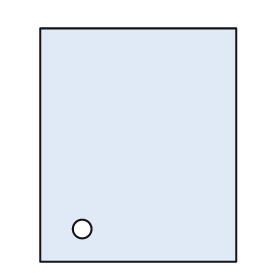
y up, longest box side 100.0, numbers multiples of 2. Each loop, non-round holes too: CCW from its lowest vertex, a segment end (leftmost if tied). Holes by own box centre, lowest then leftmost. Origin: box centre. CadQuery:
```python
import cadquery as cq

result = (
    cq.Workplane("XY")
    .moveTo(-42.0, -50.0)
    .lineTo(42.0, -50.0)
    .lineTo(42.0, 50.0)
    .lineTo(-42.0, 50.0)
    .close()
    .moveTo(-24.0, -36.0)
    .circle(4.0)
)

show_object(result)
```